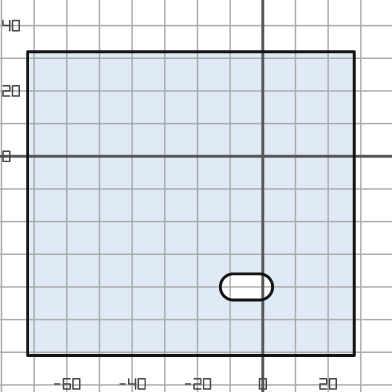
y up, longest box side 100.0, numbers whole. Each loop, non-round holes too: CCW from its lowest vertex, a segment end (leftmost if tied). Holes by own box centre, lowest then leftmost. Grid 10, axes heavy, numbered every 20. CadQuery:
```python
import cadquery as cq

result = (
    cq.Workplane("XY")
    .moveTo(-72.0, -61.0)
    .lineTo(28.0, -61.0)
    .lineTo(28.0, 32.0)
    .lineTo(-72.0, 32.0)
    .close()
    .moveTo(-9.0, -44.0)
    .lineTo(-1.0, -44.0)
    .threePointArc((3.0, -40.0), (-1.0, -36.0))
    .lineTo(-9.0, -36.0)
    .threePointArc((-13.0, -40.0), (-9.0, -44.0))
    .close()
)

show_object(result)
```